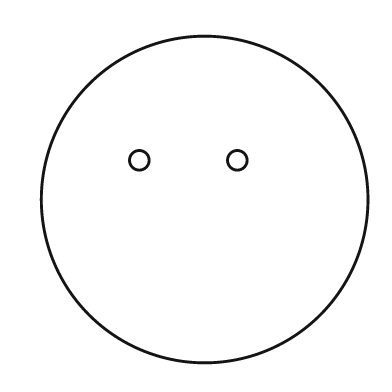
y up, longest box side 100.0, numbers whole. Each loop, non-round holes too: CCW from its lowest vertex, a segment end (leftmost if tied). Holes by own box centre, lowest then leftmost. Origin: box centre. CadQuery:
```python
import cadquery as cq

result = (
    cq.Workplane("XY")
    .moveTo(0.0, 0.0)
    .circle(50.0)
    .moveTo(-20.0, 12.0)
    .circle(3.0)
    .moveTo(10.0, 12.0)
    .circle(3.0)
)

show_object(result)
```